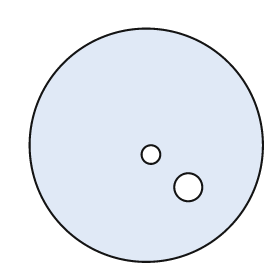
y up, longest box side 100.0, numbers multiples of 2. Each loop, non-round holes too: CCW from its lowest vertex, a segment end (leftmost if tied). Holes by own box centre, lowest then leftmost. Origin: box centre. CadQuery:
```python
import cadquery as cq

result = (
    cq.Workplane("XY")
    .moveTo(0.0, 0.0)
    .circle(50.0)
    .moveTo(18.0, -18.0)
    .circle(6.0)
    .moveTo(2.0, -4.0)
    .circle(4.0)
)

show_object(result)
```